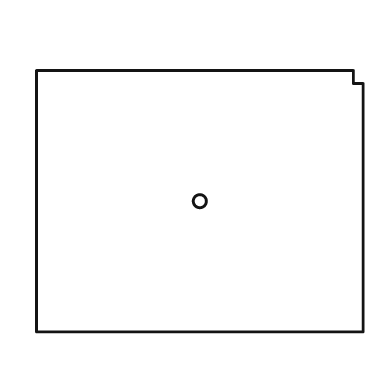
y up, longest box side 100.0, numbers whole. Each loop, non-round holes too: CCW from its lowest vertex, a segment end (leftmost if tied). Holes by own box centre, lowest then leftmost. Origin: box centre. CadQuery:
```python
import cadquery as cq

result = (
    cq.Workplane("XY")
    .moveTo(-50.0, -40.0)
    .lineTo(50.0, -40.0)
    .lineTo(50.0, 36.0)
    .lineTo(47.0, 36.0)
    .lineTo(47.0, 40.0)
    .lineTo(-50.0, 40.0)
    .close()
    .moveTo(0.0, 0.0)
    .circle(2.0)
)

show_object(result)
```